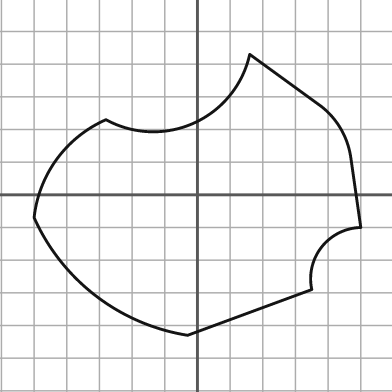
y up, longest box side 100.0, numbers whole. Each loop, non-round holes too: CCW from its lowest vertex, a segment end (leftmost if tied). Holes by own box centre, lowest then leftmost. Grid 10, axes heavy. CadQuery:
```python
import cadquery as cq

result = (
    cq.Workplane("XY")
    .moveTo(-3.0, -43.0)
    .lineTo(35.0, -29.0)
    .threePointArc((38.0, -16.0), (50.0, -10.0))
    .lineTo(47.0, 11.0)
    .threePointArc((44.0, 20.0), (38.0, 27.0))
    .lineTo(16.0, 43.0)
    .threePointArc((-1.0, 22.0), (-28.0, 23.0))
    .threePointArc((-43.0, 11.0), (-50.0, -7.0))
    .threePointArc((-31.0, -31.0), (-3.0, -43.0))
    .close()
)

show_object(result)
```